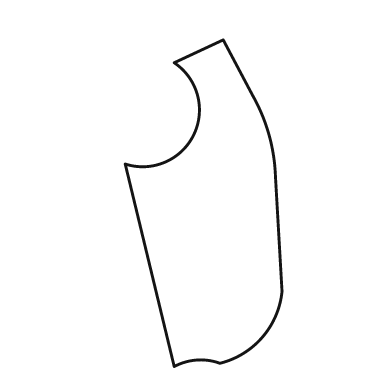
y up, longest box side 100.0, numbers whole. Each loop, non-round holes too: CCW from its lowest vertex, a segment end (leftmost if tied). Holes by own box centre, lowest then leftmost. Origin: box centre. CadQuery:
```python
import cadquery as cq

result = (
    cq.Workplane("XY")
    .moveTo(-9.0, -50.0)
    .threePointArc((-2.0, -48.0), (5.0, -49.0))
    .threePointArc((18.0, -41.0), (24.0, -27.0))
    .lineTo(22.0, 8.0)
    .threePointArc((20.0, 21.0), (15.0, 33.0))
    .lineTo(6.0, 50.0)
    .lineTo(-9.0, 43.0)
    .threePointArc((-3.0, 21.0), (-24.0, 12.0))
    .close()
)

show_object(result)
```